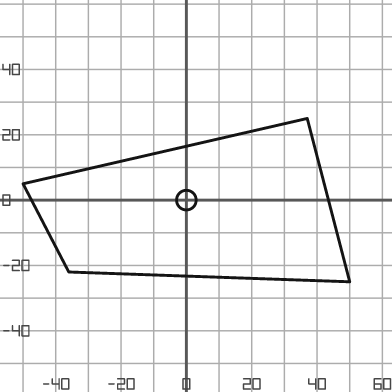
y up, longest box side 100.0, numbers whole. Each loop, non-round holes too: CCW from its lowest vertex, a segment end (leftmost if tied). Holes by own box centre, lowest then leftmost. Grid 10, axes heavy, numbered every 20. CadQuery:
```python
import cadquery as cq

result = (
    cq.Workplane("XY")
    .moveTo(50.0, -25.0)
    .lineTo(37.0, 25.0)
    .lineTo(-50.0, 5.0)
    .lineTo(-36.0, -22.0)
    .close()
    .moveTo(0.0, 0.0)
    .circle(3.0)
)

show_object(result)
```